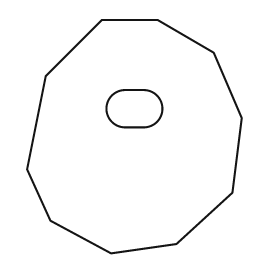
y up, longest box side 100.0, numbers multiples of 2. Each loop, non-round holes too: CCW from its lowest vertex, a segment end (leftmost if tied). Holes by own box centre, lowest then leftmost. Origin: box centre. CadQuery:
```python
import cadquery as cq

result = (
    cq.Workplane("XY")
    .moveTo(-10.0, -50.0)
    .lineTo(18.0, -46.0)
    .lineTo(42.0, -24.0)
    .lineTo(46.0, 8.0)
    .lineTo(34.0, 36.0)
    .lineTo(10.0, 50.0)
    .lineTo(-14.0, 50.0)
    .lineTo(-38.0, 26.0)
    .lineTo(-46.0, -14.0)
    .lineTo(-36.0, -36.0)
    .close()
    .moveTo(-4.0, 4.0)
    .lineTo(4.0, 4.0)
    .threePointArc((12.0, 12.0), (4.0, 20.0))
    .lineTo(-4.0, 20.0)
    .threePointArc((-12.0, 12.0), (-4.0, 4.0))
    .close()
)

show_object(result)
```